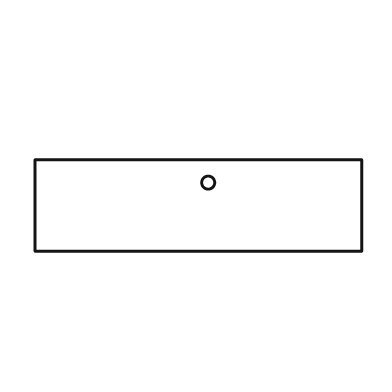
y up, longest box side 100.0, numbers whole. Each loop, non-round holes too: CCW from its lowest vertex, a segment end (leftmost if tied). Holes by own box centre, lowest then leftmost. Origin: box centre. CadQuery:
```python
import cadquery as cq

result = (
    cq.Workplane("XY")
    .moveTo(-50.0, -14.0)
    .lineTo(50.0, -14.0)
    .lineTo(50.0, 14.0)
    .lineTo(-50.0, 14.0)
    .close()
    .moveTo(3.0, 7.0)
    .circle(2.0)
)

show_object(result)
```